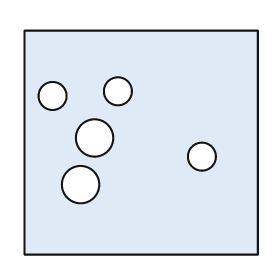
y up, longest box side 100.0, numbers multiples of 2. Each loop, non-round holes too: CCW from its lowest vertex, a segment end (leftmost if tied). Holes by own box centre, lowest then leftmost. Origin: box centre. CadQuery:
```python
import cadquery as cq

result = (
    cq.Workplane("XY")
    .moveTo(-50.0, -48.0)
    .lineTo(50.0, -48.0)
    .lineTo(50.0, 48.0)
    .lineTo(-50.0, 48.0)
    .close()
    .moveTo(-26.0, -18.0)
    .circle(8.0)
    .moveTo(26.0, -6.0)
    .circle(6.0)
    .moveTo(-20.0, 2.0)
    .circle(8.0)
    .moveTo(-38.0, 20.0)
    .circle(6.0)
    .moveTo(-10.0, 22.0)
    .circle(6.0)
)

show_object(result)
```